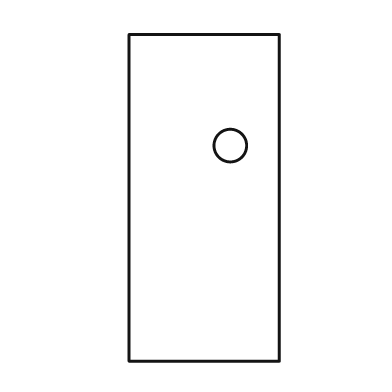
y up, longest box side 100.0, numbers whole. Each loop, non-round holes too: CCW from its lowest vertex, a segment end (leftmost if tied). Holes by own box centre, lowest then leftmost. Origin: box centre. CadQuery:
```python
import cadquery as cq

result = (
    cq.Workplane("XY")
    .moveTo(-23.0, -50.0)
    .lineTo(23.0, -50.0)
    .lineTo(23.0, 50.0)
    .lineTo(-23.0, 50.0)
    .close()
    .moveTo(8.0, 16.0)
    .circle(5.0)
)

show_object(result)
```